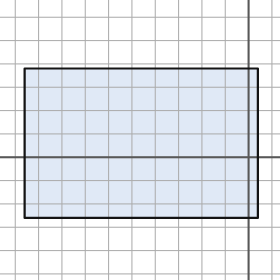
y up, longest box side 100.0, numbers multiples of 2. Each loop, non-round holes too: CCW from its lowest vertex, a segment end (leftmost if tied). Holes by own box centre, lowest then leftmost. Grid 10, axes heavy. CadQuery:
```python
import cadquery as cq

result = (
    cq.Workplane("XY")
    .moveTo(-96.0, -26.0)
    .lineTo(4.0, -26.0)
    .lineTo(4.0, 38.0)
    .lineTo(-96.0, 38.0)
    .close()
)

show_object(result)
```